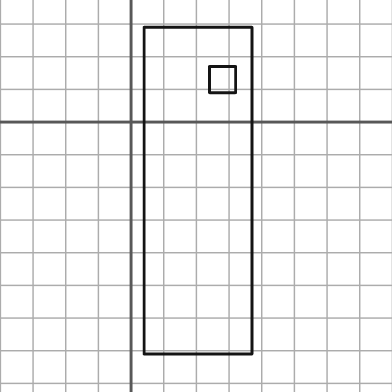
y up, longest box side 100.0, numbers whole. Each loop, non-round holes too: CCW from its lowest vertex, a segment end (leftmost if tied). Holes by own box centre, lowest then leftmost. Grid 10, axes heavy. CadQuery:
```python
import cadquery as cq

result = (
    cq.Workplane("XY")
    .moveTo(4.0, -71.0)
    .lineTo(37.0, -71.0)
    .lineTo(37.0, 29.0)
    .lineTo(4.0, 29.0)
    .close()
    .moveTo(24.0, 9.0)
    .lineTo(32.0, 9.0)
    .lineTo(32.0, 17.0)
    .lineTo(24.0, 17.0)
    .close()
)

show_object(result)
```